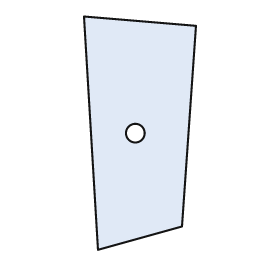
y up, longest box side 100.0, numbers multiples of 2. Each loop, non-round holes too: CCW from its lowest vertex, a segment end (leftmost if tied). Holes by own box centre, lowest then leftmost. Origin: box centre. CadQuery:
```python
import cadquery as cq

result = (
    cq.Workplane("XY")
    .moveTo(-18.0, -50.0)
    .lineTo(18.0, -40.0)
    .lineTo(24.0, 46.0)
    .lineTo(-24.0, 50.0)
    .close()
    .moveTo(-2.0, 0.0)
    .circle(4.0)
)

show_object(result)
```